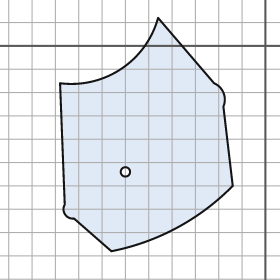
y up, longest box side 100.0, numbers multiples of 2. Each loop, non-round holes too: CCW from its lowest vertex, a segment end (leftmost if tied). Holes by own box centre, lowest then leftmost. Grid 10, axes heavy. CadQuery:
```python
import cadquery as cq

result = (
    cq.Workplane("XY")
    .moveTo(-66.0, -88.0)
    .threePointArc((-38.0, -78.0), (-14.0, -60.0))
    .lineTo(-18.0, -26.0)
    .threePointArc((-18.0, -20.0), (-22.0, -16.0))
    .lineTo(-46.0, 12.0)
    .threePointArc((-62.0, -10.0), (-88.0, -16.0))
    .lineTo(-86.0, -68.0)
    .threePointArc((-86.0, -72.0), (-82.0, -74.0))
    .close()
    .moveTo(-60.0, -54.0)
    .circle(2.0)
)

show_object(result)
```